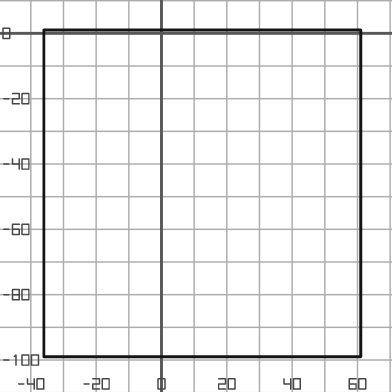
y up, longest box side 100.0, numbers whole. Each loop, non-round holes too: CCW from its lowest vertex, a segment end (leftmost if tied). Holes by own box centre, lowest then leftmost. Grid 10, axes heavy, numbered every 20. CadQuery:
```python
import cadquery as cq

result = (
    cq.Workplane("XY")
    .moveTo(-36.0, -99.0)
    .lineTo(61.0, -99.0)
    .lineTo(61.0, 1.0)
    .lineTo(-36.0, 1.0)
    .close()
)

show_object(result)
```